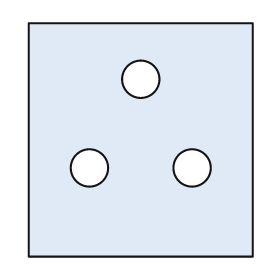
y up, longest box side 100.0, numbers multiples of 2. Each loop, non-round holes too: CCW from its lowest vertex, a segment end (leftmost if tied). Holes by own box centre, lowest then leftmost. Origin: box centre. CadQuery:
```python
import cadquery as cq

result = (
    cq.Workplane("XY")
    .moveTo(-48.0, -50.0)
    .lineTo(48.0, -50.0)
    .lineTo(48.0, 50.0)
    .lineTo(-48.0, 50.0)
    .close()
    .moveTo(-22.0, -12.0)
    .circle(8.0)
    .moveTo(22.0, -12.0)
    .circle(8.0)
    .moveTo(0.0, 26.0)
    .circle(8.0)
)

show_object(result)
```